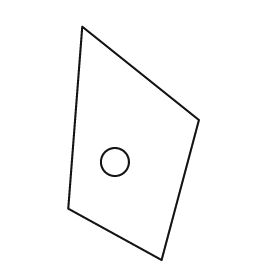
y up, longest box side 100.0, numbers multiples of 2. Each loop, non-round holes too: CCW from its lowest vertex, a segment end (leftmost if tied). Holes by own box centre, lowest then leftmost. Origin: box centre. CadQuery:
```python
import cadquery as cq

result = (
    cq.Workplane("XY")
    .moveTo(12.0, -50.0)
    .lineTo(28.0, 10.0)
    .lineTo(-22.0, 50.0)
    .lineTo(-28.0, -28.0)
    .close()
    .moveTo(-8.0, -8.0)
    .circle(6.0)
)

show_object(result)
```